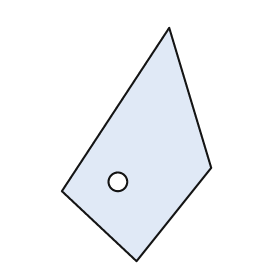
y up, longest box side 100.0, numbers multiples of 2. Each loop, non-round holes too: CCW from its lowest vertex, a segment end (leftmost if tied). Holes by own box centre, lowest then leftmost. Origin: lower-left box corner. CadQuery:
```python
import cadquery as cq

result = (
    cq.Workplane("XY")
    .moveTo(32.0, 0.0)
    .lineTo(64.0, 40.0)
    .lineTo(46.0, 100.0)
    .lineTo(0.0, 30.0)
    .close()
    .moveTo(24.0, 34.0)
    .circle(4.0)
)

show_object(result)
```